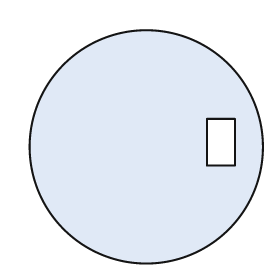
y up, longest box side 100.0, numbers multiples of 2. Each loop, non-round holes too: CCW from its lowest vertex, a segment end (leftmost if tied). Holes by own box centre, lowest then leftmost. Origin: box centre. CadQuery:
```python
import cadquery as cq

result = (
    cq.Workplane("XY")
    .moveTo(0.0, 0.0)
    .circle(50.0)
    .moveTo(26.0, -8.0)
    .lineTo(38.0, -8.0)
    .lineTo(38.0, 12.0)
    .lineTo(26.0, 12.0)
    .close()
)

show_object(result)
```